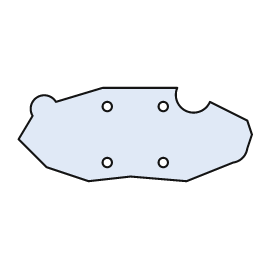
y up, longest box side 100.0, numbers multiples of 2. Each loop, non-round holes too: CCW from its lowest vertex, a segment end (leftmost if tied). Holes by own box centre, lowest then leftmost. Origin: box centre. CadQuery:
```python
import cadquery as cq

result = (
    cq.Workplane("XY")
    .moveTo(-20.0, -20.0)
    .lineTo(-2.0, -18.0)
    .lineTo(22.0, -20.0)
    .lineTo(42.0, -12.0)
    .threePointArc((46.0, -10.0), (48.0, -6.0))
    .lineTo(50.0, 0.0)
    .lineTo(48.0, 6.0)
    .lineTo(32.0, 14.0)
    .threePointArc((22.0, 10.0), (18.0, 20.0))
    .lineTo(-14.0, 20.0)
    .lineTo(-34.0, 14.0)
    .threePointArc((-42.0, 16.0), (-44.0, 8.0))
    .lineTo(-50.0, -2.0)
    .lineTo(-38.0, -14.0)
    .close()
    .moveTo(-12.0, -12.0)
    .circle(2.0)
    .moveTo(12.0, -12.0)
    .circle(2.0)
    .moveTo(-12.0, 12.0)
    .circle(2.0)
    .moveTo(12.0, 12.0)
    .circle(2.0)
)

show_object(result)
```